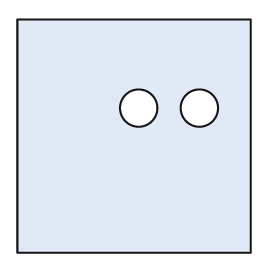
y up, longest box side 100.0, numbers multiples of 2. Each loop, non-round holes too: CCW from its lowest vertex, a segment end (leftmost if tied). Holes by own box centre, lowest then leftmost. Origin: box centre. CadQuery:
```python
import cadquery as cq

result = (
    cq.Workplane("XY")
    .moveTo(-50.0, -50.0)
    .lineTo(50.0, -50.0)
    .lineTo(50.0, 50.0)
    .lineTo(-50.0, 50.0)
    .close()
    .moveTo(2.0, 12.0)
    .circle(8.0)
    .moveTo(28.0, 12.0)
    .circle(8.0)
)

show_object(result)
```